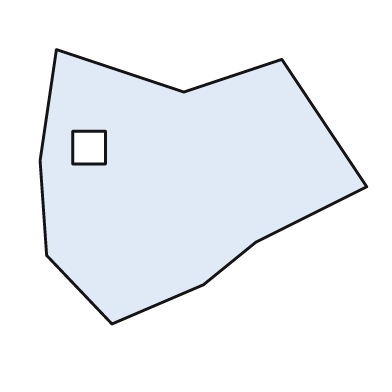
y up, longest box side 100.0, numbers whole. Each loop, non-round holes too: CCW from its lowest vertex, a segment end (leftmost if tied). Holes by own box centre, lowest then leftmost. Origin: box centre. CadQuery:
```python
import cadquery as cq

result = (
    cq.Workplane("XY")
    .moveTo(-28.0, -42.0)
    .lineTo(0.0, -30.0)
    .lineTo(16.0, -17.0)
    .lineTo(50.0, 0.0)
    .lineTo(24.0, 39.0)
    .lineTo(-6.0, 29.0)
    .lineTo(-45.0, 42.0)
    .lineTo(-50.0, 8.0)
    .lineTo(-48.0, -21.0)
    .close()
    .moveTo(-40.0, 7.0)
    .lineTo(-30.0, 7.0)
    .lineTo(-30.0, 17.0)
    .lineTo(-40.0, 17.0)
    .close()
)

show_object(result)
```